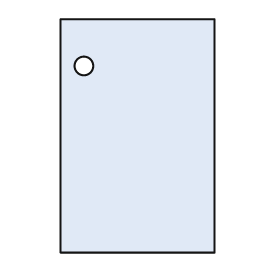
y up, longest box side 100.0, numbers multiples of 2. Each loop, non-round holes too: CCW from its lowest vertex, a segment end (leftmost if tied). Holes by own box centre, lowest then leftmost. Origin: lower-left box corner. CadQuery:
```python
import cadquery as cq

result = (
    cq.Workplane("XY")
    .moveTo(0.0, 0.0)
    .lineTo(66.0, 0.0)
    .lineTo(66.0, 100.0)
    .lineTo(0.0, 100.0)
    .close()
    .moveTo(10.0, 80.0)
    .circle(4.0)
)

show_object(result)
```